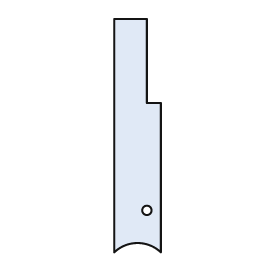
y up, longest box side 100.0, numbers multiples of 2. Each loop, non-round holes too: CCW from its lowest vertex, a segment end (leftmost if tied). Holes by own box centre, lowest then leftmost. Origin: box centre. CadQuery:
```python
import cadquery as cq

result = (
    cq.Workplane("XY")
    .moveTo(-10.0, -50.0)
    .threePointArc((0.0, -46.0), (10.0, -50.0))
    .lineTo(10.0, 14.0)
    .lineTo(4.0, 14.0)
    .lineTo(4.0, 50.0)
    .lineTo(-10.0, 50.0)
    .close()
    .moveTo(4.0, -32.0)
    .circle(2.0)
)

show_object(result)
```